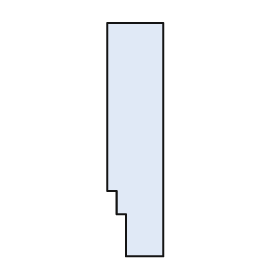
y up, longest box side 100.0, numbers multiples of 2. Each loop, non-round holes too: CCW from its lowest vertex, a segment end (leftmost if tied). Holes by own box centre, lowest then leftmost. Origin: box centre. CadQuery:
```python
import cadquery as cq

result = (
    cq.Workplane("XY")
    .moveTo(-4.0, -50.0)
    .lineTo(12.0, -50.0)
    .lineTo(12.0, 50.0)
    .lineTo(-12.0, 50.0)
    .lineTo(-12.0, -22.0)
    .lineTo(-8.0, -22.0)
    .lineTo(-8.0, -32.0)
    .lineTo(-4.0, -32.0)
    .close()
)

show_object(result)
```